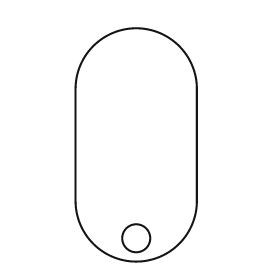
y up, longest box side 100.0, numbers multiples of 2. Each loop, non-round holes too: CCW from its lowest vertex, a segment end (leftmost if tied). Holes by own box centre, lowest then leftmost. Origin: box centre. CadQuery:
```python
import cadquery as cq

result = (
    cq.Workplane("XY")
    .moveTo(-26.0, -24.0)
    .threePointArc((0.0, -50.0), (26.0, -24.0))
    .lineTo(26.0, 24.0)
    .threePointArc((0.0, 50.0), (-26.0, 24.0))
    .close()
    .moveTo(0.0, -40.0)
    .circle(6.0)
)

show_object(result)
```